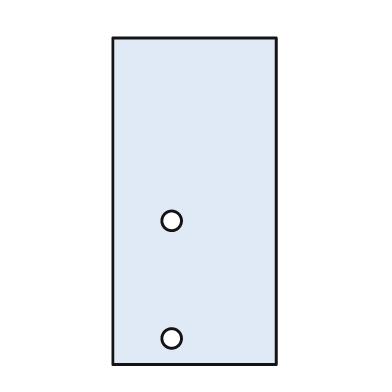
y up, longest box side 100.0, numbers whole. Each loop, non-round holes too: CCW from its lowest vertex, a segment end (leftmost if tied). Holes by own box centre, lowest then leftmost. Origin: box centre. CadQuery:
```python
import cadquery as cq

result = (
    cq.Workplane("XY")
    .moveTo(-25.0, -50.0)
    .lineTo(25.0, -50.0)
    .lineTo(25.0, 50.0)
    .lineTo(-25.0, 50.0)
    .close()
    .moveTo(-7.0, -42.0)
    .circle(3.0)
    .moveTo(-7.0, -6.0)
    .circle(3.0)
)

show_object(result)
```